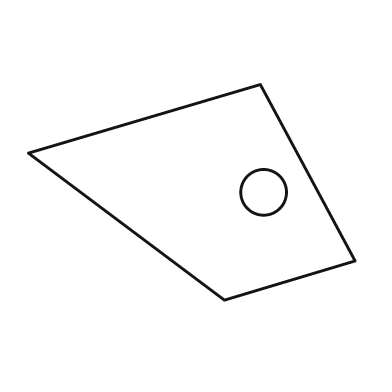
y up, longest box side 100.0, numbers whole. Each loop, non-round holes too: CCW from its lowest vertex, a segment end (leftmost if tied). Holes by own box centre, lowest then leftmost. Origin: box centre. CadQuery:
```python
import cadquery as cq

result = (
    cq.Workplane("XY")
    .moveTo(10.0, -33.0)
    .lineTo(50.0, -21.0)
    .lineTo(21.0, 33.0)
    .lineTo(-50.0, 12.0)
    .close()
    .moveTo(22.0, 0.0)
    .circle(7.0)
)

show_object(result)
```